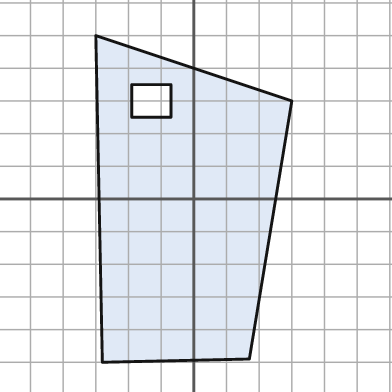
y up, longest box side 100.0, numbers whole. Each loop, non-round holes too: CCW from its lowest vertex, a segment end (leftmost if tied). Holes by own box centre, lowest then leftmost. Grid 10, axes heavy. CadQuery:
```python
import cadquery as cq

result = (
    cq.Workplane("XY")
    .moveTo(-28.0, -50.0)
    .lineTo(17.0, -49.0)
    .lineTo(30.0, 30.0)
    .lineTo(-30.0, 50.0)
    .close()
    .moveTo(-19.0, 25.0)
    .lineTo(-7.0, 25.0)
    .lineTo(-7.0, 35.0)
    .lineTo(-19.0, 35.0)
    .close()
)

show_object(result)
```